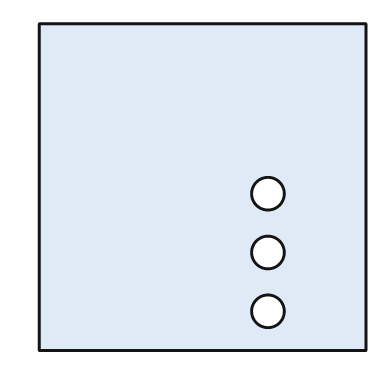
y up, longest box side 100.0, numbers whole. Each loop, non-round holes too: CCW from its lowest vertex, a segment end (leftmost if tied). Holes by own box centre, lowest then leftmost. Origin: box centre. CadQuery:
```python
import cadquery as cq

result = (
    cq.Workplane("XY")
    .moveTo(-50.0, -50.0)
    .lineTo(50.0, -50.0)
    .lineTo(50.0, 50.0)
    .lineTo(-50.0, 50.0)
    .close()
    .moveTo(20.0, -38.0)
    .circle(5.0)
    .moveTo(20.0, -20.0)
    .circle(5.0)
    .moveTo(20.0, -2.0)
    .circle(5.0)
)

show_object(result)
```